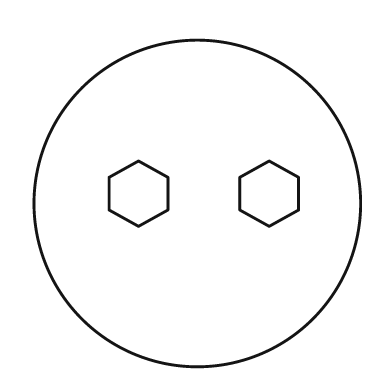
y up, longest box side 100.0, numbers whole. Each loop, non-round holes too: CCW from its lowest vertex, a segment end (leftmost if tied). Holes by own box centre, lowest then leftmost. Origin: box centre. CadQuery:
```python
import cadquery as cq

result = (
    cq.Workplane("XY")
    .moveTo(0.0, 0.0)
    .circle(50.0)
    .moveTo(-18.0, -7.0)
    .lineTo(-9.0, -2.0)
    .lineTo(-9.0, 8.0)
    .lineTo(-18.0, 13.0)
    .lineTo(-27.0, 8.0)
    .lineTo(-27.0, -2.0)
    .close()
    .moveTo(22.0, -7.0)
    .lineTo(31.0, -2.0)
    .lineTo(31.0, 8.0)
    .lineTo(22.0, 13.0)
    .lineTo(13.0, 8.0)
    .lineTo(13.0, -2.0)
    .close()
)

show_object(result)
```